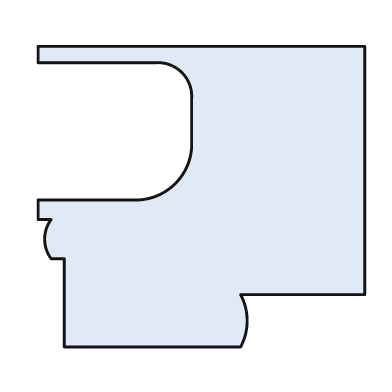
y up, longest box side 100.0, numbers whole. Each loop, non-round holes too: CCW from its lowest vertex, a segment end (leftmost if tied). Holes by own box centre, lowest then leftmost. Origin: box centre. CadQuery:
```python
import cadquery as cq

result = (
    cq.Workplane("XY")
    .moveTo(-42.0, -46.0)
    .lineTo(12.0, -46.0)
    .threePointArc((14.0, -38.0), (12.0, -30.0))
    .lineTo(50.0, -30.0)
    .lineTo(50.0, 46.0)
    .lineTo(-50.0, 46.0)
    .lineTo(-50.0, 41.0)
    .lineTo(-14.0, 41.0)
    .threePointArc((-6.0, 38.0), (-3.0, 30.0))
    .lineTo(-3.0, 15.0)
    .threePointArc((-8.0, 4.0), (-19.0, -1.0))
    .lineTo(-50.0, -1.0)
    .lineTo(-50.0, -7.0)
    .lineTo(-46.0, -7.0)
    .threePointArc((-48.0, -13.0), (-46.0, -19.0))
    .lineTo(-42.0, -19.0)
    .close()
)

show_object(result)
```